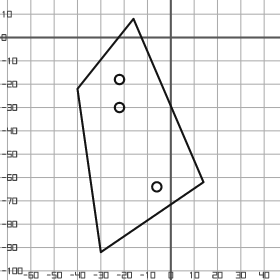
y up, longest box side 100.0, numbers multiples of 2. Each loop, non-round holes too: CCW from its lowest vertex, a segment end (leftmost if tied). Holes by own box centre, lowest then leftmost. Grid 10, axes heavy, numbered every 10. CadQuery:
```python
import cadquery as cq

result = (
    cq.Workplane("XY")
    .moveTo(-30.0, -92.0)
    .lineTo(14.0, -62.0)
    .lineTo(-16.0, 8.0)
    .lineTo(-40.0, -22.0)
    .close()
    .moveTo(-6.0, -64.0)
    .circle(2.0)
    .moveTo(-22.0, -30.0)
    .circle(2.0)
    .moveTo(-22.0, -18.0)
    .circle(2.0)
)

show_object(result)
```